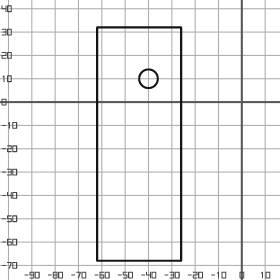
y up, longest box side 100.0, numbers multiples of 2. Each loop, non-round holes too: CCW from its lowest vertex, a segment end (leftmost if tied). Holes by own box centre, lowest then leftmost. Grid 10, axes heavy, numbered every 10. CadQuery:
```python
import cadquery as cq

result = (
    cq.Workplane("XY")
    .moveTo(-62.0, -68.0)
    .lineTo(-26.0, -68.0)
    .lineTo(-26.0, 32.0)
    .lineTo(-62.0, 32.0)
    .close()
    .moveTo(-40.0, 10.0)
    .circle(4.0)
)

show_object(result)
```